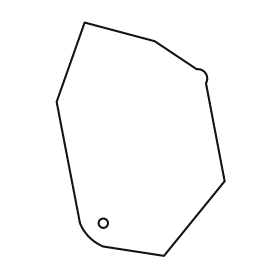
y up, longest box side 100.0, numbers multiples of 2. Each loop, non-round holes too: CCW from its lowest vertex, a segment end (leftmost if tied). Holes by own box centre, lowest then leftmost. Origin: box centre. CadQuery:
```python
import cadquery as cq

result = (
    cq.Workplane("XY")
    .moveTo(10.0, -50.0)
    .lineTo(36.0, -18.0)
    .lineTo(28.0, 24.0)
    .threePointArc((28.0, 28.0), (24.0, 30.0))
    .lineTo(6.0, 42.0)
    .lineTo(-24.0, 50.0)
    .lineTo(-36.0, 16.0)
    .lineTo(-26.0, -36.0)
    .threePointArc((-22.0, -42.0), (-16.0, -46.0))
    .close()
    .moveTo(-16.0, -36.0)
    .circle(2.0)
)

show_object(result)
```